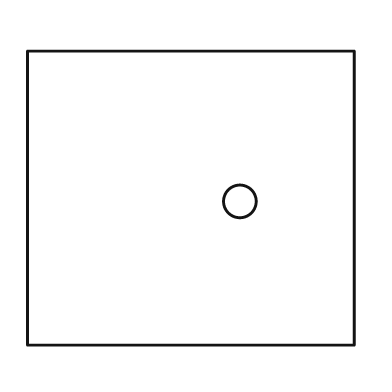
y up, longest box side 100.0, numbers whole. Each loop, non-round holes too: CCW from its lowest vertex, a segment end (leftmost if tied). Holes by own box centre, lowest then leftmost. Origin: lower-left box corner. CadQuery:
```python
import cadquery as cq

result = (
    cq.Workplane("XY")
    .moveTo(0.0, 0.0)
    .lineTo(100.0, 0.0)
    .lineTo(100.0, 90.0)
    .lineTo(0.0, 90.0)
    .close()
    .moveTo(65.0, 44.0)
    .circle(5.0)
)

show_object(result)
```